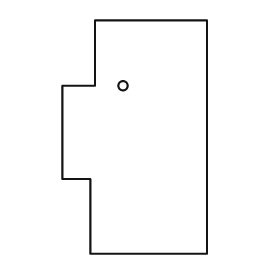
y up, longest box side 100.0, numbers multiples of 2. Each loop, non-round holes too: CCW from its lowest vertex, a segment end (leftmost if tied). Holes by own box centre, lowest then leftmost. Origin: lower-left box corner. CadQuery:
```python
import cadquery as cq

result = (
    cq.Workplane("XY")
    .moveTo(12.0, 0.0)
    .lineTo(62.0, 0.0)
    .lineTo(62.0, 100.0)
    .lineTo(14.0, 100.0)
    .lineTo(14.0, 72.0)
    .lineTo(0.0, 72.0)
    .lineTo(0.0, 32.0)
    .lineTo(12.0, 32.0)
    .close()
    .moveTo(26.0, 72.0)
    .circle(2.0)
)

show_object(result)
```